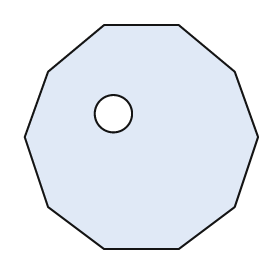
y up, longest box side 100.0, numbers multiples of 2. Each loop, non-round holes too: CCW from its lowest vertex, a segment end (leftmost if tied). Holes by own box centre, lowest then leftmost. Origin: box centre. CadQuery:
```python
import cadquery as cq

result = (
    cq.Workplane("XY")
    .moveTo(-16.0, -48.0)
    .lineTo(16.0, -48.0)
    .lineTo(40.0, -30.0)
    .lineTo(50.0, 0.0)
    .lineTo(40.0, 28.0)
    .lineTo(16.0, 48.0)
    .lineTo(-16.0, 48.0)
    .lineTo(-40.0, 28.0)
    .lineTo(-50.0, 0.0)
    .lineTo(-40.0, -30.0)
    .close()
    .moveTo(-12.0, 10.0)
    .circle(8.0)
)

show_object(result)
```